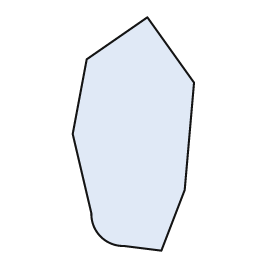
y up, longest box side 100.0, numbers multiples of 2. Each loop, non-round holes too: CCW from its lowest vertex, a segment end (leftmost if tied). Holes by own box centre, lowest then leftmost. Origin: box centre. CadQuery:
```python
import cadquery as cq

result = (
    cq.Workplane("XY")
    .moveTo(12.0, -50.0)
    .lineTo(22.0, -24.0)
    .lineTo(26.0, 22.0)
    .lineTo(6.0, 50.0)
    .lineTo(-20.0, 32.0)
    .lineTo(-26.0, 0.0)
    .lineTo(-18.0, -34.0)
    .threePointArc((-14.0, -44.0), (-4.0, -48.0))
    .close()
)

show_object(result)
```